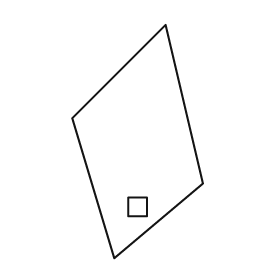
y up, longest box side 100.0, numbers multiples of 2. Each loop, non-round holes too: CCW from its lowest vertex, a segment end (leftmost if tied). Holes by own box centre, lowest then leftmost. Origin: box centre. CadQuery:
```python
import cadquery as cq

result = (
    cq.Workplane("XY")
    .moveTo(-10.0, -50.0)
    .lineTo(28.0, -18.0)
    .lineTo(12.0, 50.0)
    .lineTo(-28.0, 10.0)
    .close()
    .moveTo(-4.0, -32.0)
    .lineTo(4.0, -32.0)
    .lineTo(4.0, -24.0)
    .lineTo(-4.0, -24.0)
    .close()
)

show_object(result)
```